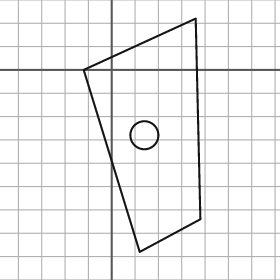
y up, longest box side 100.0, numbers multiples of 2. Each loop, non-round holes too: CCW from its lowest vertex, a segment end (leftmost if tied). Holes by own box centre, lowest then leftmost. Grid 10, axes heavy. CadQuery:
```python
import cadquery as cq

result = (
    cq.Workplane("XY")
    .moveTo(12.0, -78.0)
    .lineTo(38.0, -64.0)
    .lineTo(36.0, 22.0)
    .lineTo(-12.0, 0.0)
    .close()
    .moveTo(14.0, -28.0)
    .circle(6.0)
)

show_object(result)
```